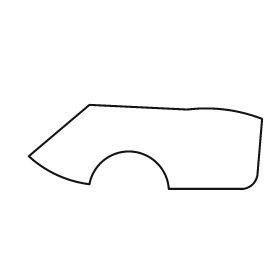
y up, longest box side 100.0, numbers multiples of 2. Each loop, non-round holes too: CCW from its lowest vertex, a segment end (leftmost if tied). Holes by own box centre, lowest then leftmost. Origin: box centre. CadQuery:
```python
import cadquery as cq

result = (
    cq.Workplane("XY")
    .moveTo(10.0, -18.0)
    .lineTo(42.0, -18.0)
    .threePointArc((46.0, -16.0), (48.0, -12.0))
    .lineTo(50.0, 12.0)
    .threePointArc((34.0, 16.0), (18.0, 16.0))
    .lineTo(-24.0, 18.0)
    .lineTo(-50.0, -4.0)
    .threePointArc((-38.0, -12.0), (-24.0, -16.0))
    .threePointArc((-6.0, -2.0), (10.0, -18.0))
    .close()
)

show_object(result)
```